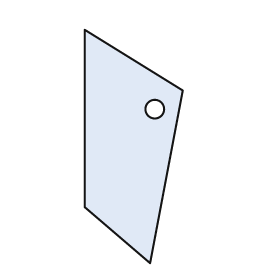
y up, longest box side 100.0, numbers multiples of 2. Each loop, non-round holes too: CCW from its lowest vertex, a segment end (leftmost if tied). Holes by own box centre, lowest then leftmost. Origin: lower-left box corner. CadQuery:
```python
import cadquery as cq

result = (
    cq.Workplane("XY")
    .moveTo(28.0, 0.0)
    .lineTo(42.0, 74.0)
    .lineTo(0.0, 100.0)
    .lineTo(0.0, 24.0)
    .close()
    .moveTo(30.0, 66.0)
    .circle(4.0)
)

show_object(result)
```